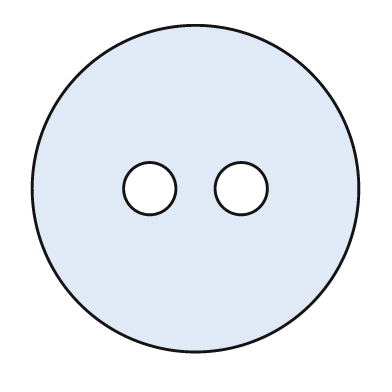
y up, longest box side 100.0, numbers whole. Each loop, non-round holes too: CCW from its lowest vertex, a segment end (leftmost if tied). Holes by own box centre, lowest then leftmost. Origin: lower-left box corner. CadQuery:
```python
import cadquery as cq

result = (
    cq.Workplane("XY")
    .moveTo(50.0, 50.0)
    .circle(50.0)
    .moveTo(36.0, 50.0)
    .circle(8.0)
    .moveTo(64.0, 50.0)
    .circle(8.0)
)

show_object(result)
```